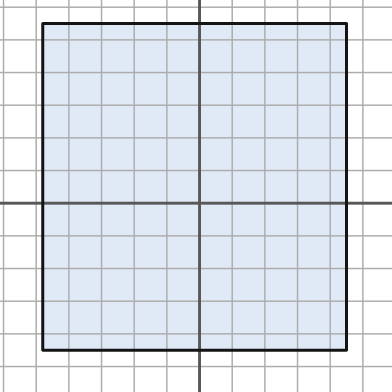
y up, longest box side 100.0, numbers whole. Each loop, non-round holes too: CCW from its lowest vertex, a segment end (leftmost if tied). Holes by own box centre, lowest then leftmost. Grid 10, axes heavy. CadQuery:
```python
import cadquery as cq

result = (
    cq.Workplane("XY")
    .moveTo(-48.0, -45.0)
    .lineTo(45.0, -45.0)
    .lineTo(45.0, 55.0)
    .lineTo(-48.0, 55.0)
    .close()
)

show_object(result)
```